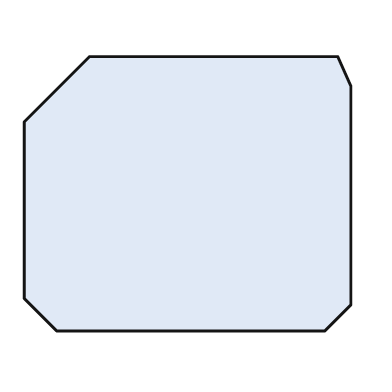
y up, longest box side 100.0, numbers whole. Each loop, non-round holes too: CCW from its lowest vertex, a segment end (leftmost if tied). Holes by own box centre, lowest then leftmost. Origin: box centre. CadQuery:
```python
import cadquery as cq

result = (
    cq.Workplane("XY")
    .moveTo(-40.0, -42.0)
    .lineTo(42.0, -42.0)
    .lineTo(50.0, -34.0)
    .lineTo(50.0, 33.0)
    .lineTo(46.0, 42.0)
    .lineTo(-30.0, 42.0)
    .lineTo(-50.0, 22.0)
    .lineTo(-50.0, -32.0)
    .close()
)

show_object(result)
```